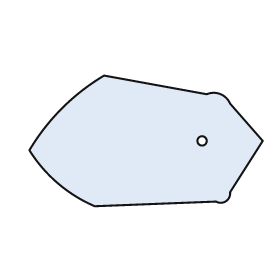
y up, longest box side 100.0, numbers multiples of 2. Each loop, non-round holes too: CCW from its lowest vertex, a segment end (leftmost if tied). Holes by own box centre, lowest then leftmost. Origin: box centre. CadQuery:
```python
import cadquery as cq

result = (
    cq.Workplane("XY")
    .moveTo(-22.0, -28.0)
    .lineTo(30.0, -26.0)
    .threePointArc((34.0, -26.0), (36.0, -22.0))
    .lineTo(50.0, 0.0)
    .lineTo(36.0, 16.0)
    .threePointArc((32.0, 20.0), (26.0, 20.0))
    .lineTo(-18.0, 28.0)
    .threePointArc((-36.0, 14.0), (-50.0, -4.0))
    .threePointArc((-38.0, -18.0), (-22.0, -28.0))
    .close()
    .moveTo(24.0, 0.0)
    .circle(2.0)
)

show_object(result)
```